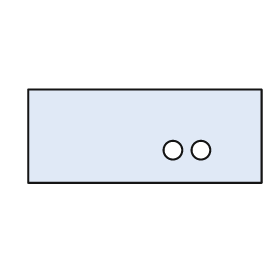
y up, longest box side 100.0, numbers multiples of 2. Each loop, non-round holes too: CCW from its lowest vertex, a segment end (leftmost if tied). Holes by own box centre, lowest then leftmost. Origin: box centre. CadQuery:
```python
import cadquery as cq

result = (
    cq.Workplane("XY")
    .moveTo(-50.0, -20.0)
    .lineTo(50.0, -20.0)
    .lineTo(50.0, 20.0)
    .lineTo(-50.0, 20.0)
    .close()
    .moveTo(12.0, -6.0)
    .circle(4.0)
    .moveTo(24.0, -6.0)
    .circle(4.0)
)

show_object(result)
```